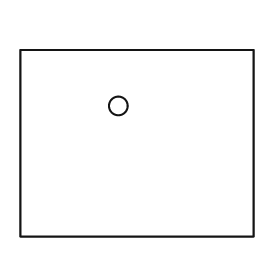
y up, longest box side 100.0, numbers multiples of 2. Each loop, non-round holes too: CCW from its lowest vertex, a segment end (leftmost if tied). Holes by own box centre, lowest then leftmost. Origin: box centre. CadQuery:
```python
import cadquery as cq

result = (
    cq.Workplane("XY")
    .moveTo(-50.0, -40.0)
    .lineTo(50.0, -40.0)
    .lineTo(50.0, 40.0)
    .lineTo(-50.0, 40.0)
    .close()
    .moveTo(-8.0, 16.0)
    .circle(4.0)
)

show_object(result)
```